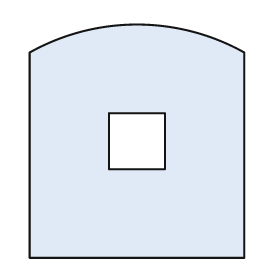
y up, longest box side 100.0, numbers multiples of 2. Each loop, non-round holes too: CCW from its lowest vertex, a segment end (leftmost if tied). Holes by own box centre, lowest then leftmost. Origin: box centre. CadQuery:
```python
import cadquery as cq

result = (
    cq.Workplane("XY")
    .moveTo(-46.0, -50.0)
    .lineTo(46.0, -50.0)
    .lineTo(46.0, 38.0)
    .threePointArc((0.0, 50.0), (-46.0, 38.0))
    .close()
    .moveTo(-12.0, -12.0)
    .lineTo(12.0, -12.0)
    .lineTo(12.0, 12.0)
    .lineTo(-12.0, 12.0)
    .close()
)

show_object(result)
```